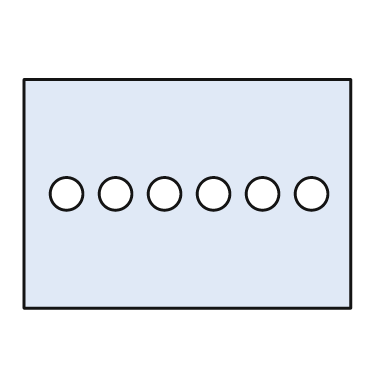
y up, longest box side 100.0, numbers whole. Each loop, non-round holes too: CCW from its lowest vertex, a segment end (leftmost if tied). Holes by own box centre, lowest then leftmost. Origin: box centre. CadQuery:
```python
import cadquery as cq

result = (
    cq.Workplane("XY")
    .moveTo(-50.0, -35.0)
    .lineTo(50.0, -35.0)
    .lineTo(50.0, 35.0)
    .lineTo(-50.0, 35.0)
    .close()
    .moveTo(-37.0, 0.0)
    .circle(5.0)
    .moveTo(-22.0, 0.0)
    .circle(5.0)
    .moveTo(-7.0, 0.0)
    .circle(5.0)
    .moveTo(8.0, 0.0)
    .circle(5.0)
    .moveTo(23.0, 0.0)
    .circle(5.0)
    .moveTo(38.0, 0.0)
    .circle(5.0)
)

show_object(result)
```